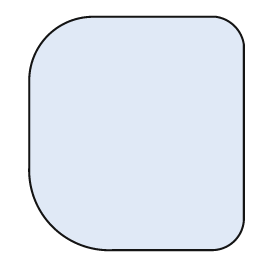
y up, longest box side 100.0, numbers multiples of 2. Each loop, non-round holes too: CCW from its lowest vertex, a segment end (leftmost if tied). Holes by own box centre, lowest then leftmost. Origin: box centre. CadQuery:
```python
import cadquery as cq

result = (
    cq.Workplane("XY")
    .moveTo(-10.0, -50.0)
    .lineTo(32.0, -50.0)
    .threePointArc((42.0, -46.0), (46.0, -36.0))
    .lineTo(46.0, 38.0)
    .threePointArc((42.0, 46.0), (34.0, 50.0))
    .lineTo(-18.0, 50.0)
    .threePointArc((-38.0, 42.0), (-46.0, 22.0))
    .lineTo(-46.0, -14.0)
    .threePointArc((-36.0, -40.0), (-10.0, -50.0))
    .close()
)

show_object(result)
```